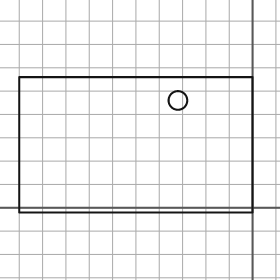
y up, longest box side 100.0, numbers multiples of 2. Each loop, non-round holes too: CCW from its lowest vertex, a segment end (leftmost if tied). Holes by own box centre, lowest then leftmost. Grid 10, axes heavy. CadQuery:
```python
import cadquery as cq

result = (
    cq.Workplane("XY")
    .moveTo(-100.0, -2.0)
    .lineTo(0.0, -2.0)
    .lineTo(0.0, 56.0)
    .lineTo(-100.0, 56.0)
    .close()
    .moveTo(-32.0, 46.0)
    .circle(4.0)
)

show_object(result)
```